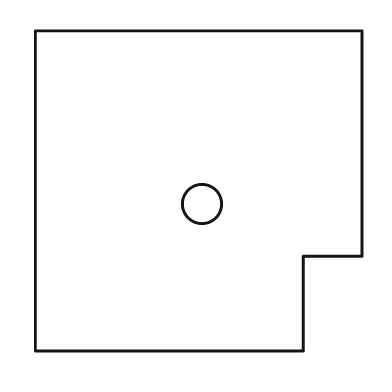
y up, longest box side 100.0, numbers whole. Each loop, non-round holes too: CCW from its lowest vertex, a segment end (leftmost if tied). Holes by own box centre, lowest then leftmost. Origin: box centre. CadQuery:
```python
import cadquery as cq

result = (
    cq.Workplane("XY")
    .moveTo(-50.0, -49.0)
    .lineTo(32.0, -49.0)
    .lineTo(32.0, -20.0)
    .lineTo(50.0, -20.0)
    .lineTo(50.0, 49.0)
    .lineTo(-50.0, 49.0)
    .close()
    .moveTo(1.0, -4.0)
    .circle(6.0)
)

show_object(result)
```